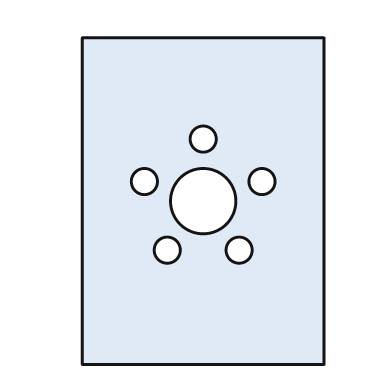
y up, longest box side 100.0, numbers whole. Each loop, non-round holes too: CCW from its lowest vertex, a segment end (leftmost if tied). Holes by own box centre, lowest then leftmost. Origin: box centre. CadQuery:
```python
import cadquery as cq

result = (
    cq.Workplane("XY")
    .moveTo(-37.0, -50.0)
    .lineTo(37.0, -50.0)
    .lineTo(37.0, 50.0)
    .lineTo(-37.0, 50.0)
    .close()
    .moveTo(-11.0, -15.0)
    .circle(4.0)
    .moveTo(11.0, -15.0)
    .circle(4.0)
    .moveTo(0.0, 0.0)
    .circle(10.0)
    .moveTo(-18.0, 6.0)
    .circle(4.0)
    .moveTo(18.0, 6.0)
    .circle(4.0)
    .moveTo(0.0, 19.0)
    .circle(4.0)
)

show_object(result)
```